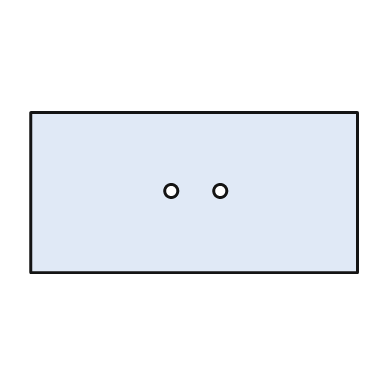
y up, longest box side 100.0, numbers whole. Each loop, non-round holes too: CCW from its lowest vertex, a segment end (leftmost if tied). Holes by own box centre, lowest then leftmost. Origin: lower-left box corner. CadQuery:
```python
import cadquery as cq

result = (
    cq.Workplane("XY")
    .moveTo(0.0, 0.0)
    .lineTo(100.0, 0.0)
    .lineTo(100.0, 49.0)
    .lineTo(0.0, 49.0)
    .close()
    .moveTo(43.0, 25.0)
    .circle(2.0)
    .moveTo(58.0, 25.0)
    .circle(2.0)
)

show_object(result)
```